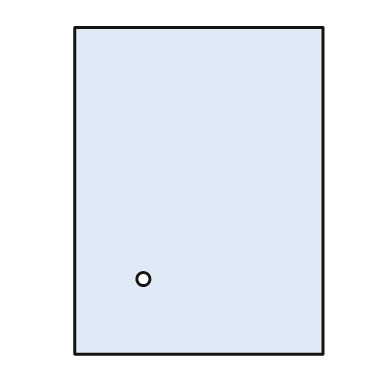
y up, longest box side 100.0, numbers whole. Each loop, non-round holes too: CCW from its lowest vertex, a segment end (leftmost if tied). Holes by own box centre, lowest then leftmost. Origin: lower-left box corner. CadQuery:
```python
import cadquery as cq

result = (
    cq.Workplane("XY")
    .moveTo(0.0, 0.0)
    .lineTo(76.0, 0.0)
    .lineTo(76.0, 100.0)
    .lineTo(0.0, 100.0)
    .close()
    .moveTo(21.0, 23.0)
    .circle(2.0)
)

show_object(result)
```